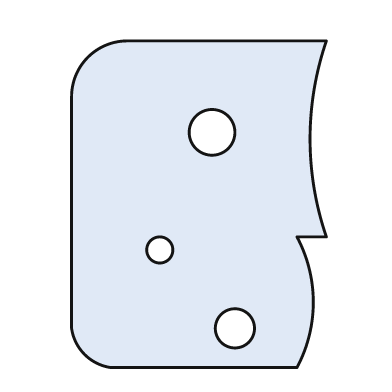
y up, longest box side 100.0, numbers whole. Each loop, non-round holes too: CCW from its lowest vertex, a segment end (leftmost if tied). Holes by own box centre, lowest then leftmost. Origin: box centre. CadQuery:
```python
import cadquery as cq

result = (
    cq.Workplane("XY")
    .moveTo(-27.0, -50.0)
    .lineTo(30.0, -50.0)
    .threePointArc((35.0, -30.0), (30.0, -10.0))
    .lineTo(39.0, -10.0)
    .threePointArc((34.0, 20.0), (39.0, 50.0))
    .lineTo(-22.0, 50.0)
    .threePointArc((-34.0, 45.0), (-39.0, 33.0))
    .lineTo(-39.0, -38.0)
    .threePointArc((-35.0, -46.0), (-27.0, -50.0))
    .close()
    .moveTo(11.0, -38.0)
    .circle(6.0)
    .moveTo(-12.0, -14.0)
    .circle(4.0)
    .moveTo(4.0, 22.0)
    .circle(7.0)
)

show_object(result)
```